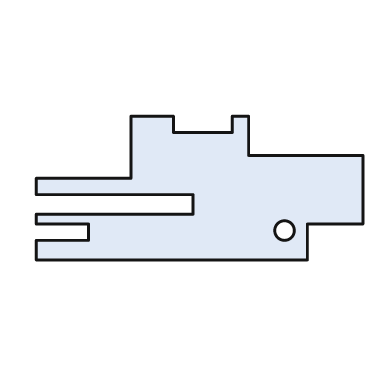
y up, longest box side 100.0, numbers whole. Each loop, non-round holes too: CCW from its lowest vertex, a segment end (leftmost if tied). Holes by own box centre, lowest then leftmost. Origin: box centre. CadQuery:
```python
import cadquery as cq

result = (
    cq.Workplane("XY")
    .moveTo(-50.0, -22.0)
    .lineTo(33.0, -22.0)
    .lineTo(33.0, -11.0)
    .lineTo(50.0, -11.0)
    .lineTo(50.0, 10.0)
    .lineTo(15.0, 10.0)
    .lineTo(15.0, 22.0)
    .lineTo(10.0, 22.0)
    .lineTo(10.0, 17.0)
    .lineTo(-8.0, 17.0)
    .lineTo(-8.0, 22.0)
    .lineTo(-21.0, 22.0)
    .lineTo(-21.0, 3.0)
    .lineTo(-50.0, 3.0)
    .lineTo(-50.0, -2.0)
    .lineTo(-2.0, -2.0)
    .lineTo(-2.0, -8.0)
    .lineTo(-50.0, -8.0)
    .lineTo(-50.0, -11.0)
    .lineTo(-34.0, -11.0)
    .lineTo(-34.0, -16.0)
    .lineTo(-50.0, -16.0)
    .close()
    .moveTo(26.0, -13.0)
    .circle(3.0)
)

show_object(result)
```